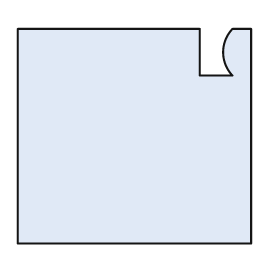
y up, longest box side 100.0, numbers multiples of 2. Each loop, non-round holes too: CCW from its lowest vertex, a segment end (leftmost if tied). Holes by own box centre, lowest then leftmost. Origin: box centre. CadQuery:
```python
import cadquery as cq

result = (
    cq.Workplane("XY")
    .moveTo(-50.0, -46.0)
    .lineTo(50.0, -46.0)
    .lineTo(50.0, 46.0)
    .lineTo(42.0, 46.0)
    .threePointArc((38.0, 36.0), (42.0, 26.0))
    .lineTo(28.0, 26.0)
    .lineTo(28.0, 46.0)
    .lineTo(-50.0, 46.0)
    .close()
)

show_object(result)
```